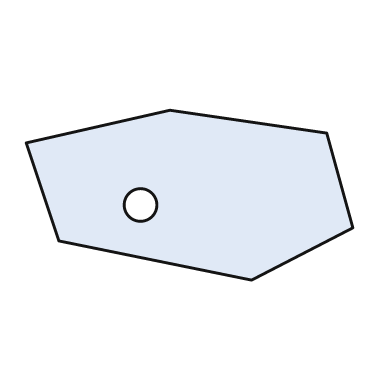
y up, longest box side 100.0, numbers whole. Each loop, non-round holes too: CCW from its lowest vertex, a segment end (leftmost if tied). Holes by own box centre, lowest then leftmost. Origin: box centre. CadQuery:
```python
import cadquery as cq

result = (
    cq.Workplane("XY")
    .moveTo(19.0, -26.0)
    .lineTo(50.0, -10.0)
    .lineTo(42.0, 19.0)
    .lineTo(-6.0, 26.0)
    .lineTo(-50.0, 16.0)
    .lineTo(-40.0, -14.0)
    .close()
    .moveTo(-15.0, -3.0)
    .circle(5.0)
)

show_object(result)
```